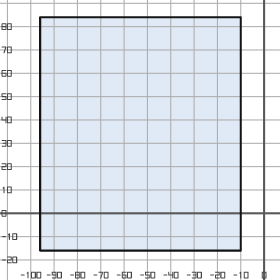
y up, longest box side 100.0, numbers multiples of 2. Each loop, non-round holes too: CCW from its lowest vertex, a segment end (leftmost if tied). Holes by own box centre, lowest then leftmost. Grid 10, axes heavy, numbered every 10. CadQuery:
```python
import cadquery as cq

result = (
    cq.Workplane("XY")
    .moveTo(-96.0, -16.0)
    .lineTo(-10.0, -16.0)
    .lineTo(-10.0, 84.0)
    .lineTo(-96.0, 84.0)
    .close()
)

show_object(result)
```